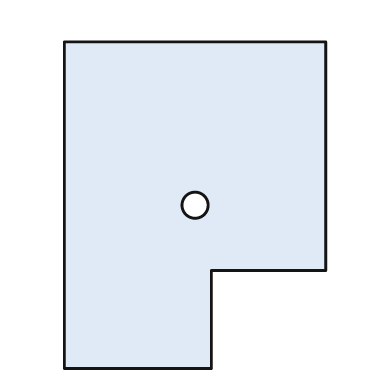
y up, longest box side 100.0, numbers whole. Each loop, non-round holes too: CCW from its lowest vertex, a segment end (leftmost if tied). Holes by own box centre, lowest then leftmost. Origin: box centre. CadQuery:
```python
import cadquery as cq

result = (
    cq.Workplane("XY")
    .moveTo(-40.0, -50.0)
    .lineTo(5.0, -50.0)
    .lineTo(5.0, -20.0)
    .lineTo(40.0, -20.0)
    .lineTo(40.0, 50.0)
    .lineTo(-40.0, 50.0)
    .close()
    .moveTo(0.0, 0.0)
    .circle(4.0)
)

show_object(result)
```